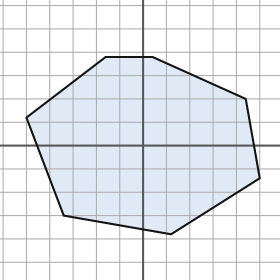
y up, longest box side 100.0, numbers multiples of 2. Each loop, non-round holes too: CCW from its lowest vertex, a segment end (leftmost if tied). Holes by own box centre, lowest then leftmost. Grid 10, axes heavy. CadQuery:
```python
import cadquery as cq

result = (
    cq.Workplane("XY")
    .moveTo(12.0, -38.0)
    .lineTo(50.0, -14.0)
    .lineTo(44.0, 20.0)
    .lineTo(4.0, 38.0)
    .lineTo(-16.0, 38.0)
    .lineTo(-50.0, 12.0)
    .lineTo(-34.0, -30.0)
    .close()
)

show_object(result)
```